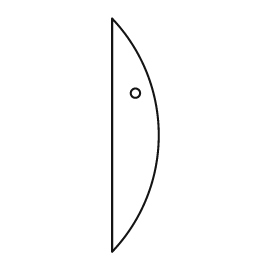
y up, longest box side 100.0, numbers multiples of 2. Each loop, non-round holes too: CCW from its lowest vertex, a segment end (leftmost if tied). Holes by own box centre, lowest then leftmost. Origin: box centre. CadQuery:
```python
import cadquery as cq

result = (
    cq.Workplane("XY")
    .moveTo(-10.0, -50.0)
    .threePointArc((10.0, 0.0), (-10.0, 50.0))
    .close()
    .moveTo(0.0, 18.0)
    .circle(2.0)
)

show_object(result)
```